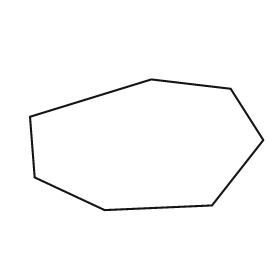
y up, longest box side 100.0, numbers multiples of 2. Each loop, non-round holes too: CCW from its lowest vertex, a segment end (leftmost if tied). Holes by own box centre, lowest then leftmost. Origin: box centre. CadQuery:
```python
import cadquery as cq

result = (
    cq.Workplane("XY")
    .moveTo(-18.0, -28.0)
    .lineTo(28.0, -26.0)
    .lineTo(50.0, 2.0)
    .lineTo(36.0, 24.0)
    .lineTo(2.0, 28.0)
    .lineTo(-50.0, 12.0)
    .lineTo(-48.0, -14.0)
    .close()
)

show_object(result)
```